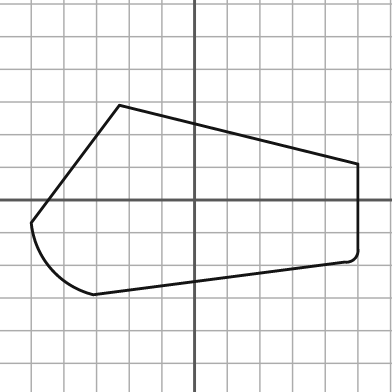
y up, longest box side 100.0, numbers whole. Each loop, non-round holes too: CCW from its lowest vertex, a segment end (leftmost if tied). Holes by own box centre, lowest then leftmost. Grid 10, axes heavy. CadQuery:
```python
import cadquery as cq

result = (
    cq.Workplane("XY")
    .moveTo(-31.0, -29.0)
    .lineTo(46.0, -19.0)
    .threePointArc((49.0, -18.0), (50.0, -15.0))
    .lineTo(50.0, 11.0)
    .lineTo(-23.0, 29.0)
    .lineTo(-50.0, -7.0)
    .threePointArc((-44.0, -21.0), (-31.0, -29.0))
    .close()
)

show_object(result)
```